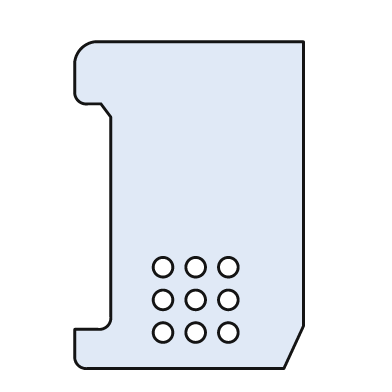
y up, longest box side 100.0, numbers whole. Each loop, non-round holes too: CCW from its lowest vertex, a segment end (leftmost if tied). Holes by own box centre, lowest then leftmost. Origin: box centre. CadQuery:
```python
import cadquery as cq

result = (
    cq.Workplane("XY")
    .moveTo(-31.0, -50.0)
    .lineTo(29.0, -50.0)
    .lineTo(35.0, -37.0)
    .lineTo(35.0, 50.0)
    .lineTo(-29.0, 50.0)
    .threePointArc((-33.0, 48.0), (-35.0, 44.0))
    .lineTo(-35.0, 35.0)
    .threePointArc((-34.0, 32.0), (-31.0, 31.0))
    .lineTo(-27.0, 31.0)
    .lineTo(-24.0, 27.0)
    .lineTo(-24.0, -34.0)
    .threePointArc((-25.0, -37.0), (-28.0, -38.0))
    .lineTo(-35.0, -38.0)
    .lineTo(-35.0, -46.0)
    .threePointArc((-34.0, -49.0), (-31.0, -50.0))
    .close()
    .moveTo(-8.0, -39.0)
    .circle(3.0)
    .moveTo(2.0, -39.0)
    .circle(3.0)
    .moveTo(12.0, -39.0)
    .circle(3.0)
    .moveTo(-8.0, -29.0)
    .circle(3.0)
    .moveTo(2.0, -29.0)
    .circle(3.0)
    .moveTo(12.0, -29.0)
    .circle(3.0)
    .moveTo(-8.0, -19.0)
    .circle(3.0)
    .moveTo(2.0, -19.0)
    .circle(3.0)
    .moveTo(12.0, -19.0)
    .circle(3.0)
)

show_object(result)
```